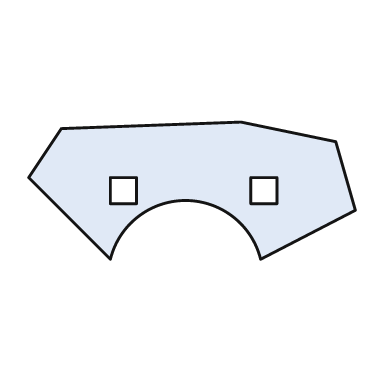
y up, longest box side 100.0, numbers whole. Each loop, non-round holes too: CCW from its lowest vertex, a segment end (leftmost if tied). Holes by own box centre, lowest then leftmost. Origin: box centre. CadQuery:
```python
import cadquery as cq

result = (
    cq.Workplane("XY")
    .moveTo(-25.0, -21.0)
    .threePointArc((-2.0, -3.0), (21.0, -21.0))
    .lineTo(50.0, -6.0)
    .lineTo(44.0, 15.0)
    .lineTo(15.0, 21.0)
    .lineTo(-40.0, 19.0)
    .lineTo(-50.0, 4.0)
    .close()
    .moveTo(-25.0, -4.0)
    .lineTo(-17.0, -4.0)
    .lineTo(-17.0, 4.0)
    .lineTo(-25.0, 4.0)
    .close()
    .moveTo(18.0, -4.0)
    .lineTo(26.0, -4.0)
    .lineTo(26.0, 4.0)
    .lineTo(18.0, 4.0)
    .close()
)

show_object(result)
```